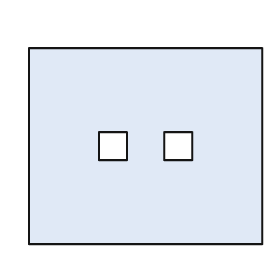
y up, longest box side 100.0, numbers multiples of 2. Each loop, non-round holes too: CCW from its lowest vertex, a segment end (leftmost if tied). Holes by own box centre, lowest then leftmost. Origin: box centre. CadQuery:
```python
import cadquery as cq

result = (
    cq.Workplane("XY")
    .moveTo(-50.0, -42.0)
    .lineTo(50.0, -42.0)
    .lineTo(50.0, 42.0)
    .lineTo(-50.0, 42.0)
    .close()
    .moveTo(-20.0, -6.0)
    .lineTo(-8.0, -6.0)
    .lineTo(-8.0, 6.0)
    .lineTo(-20.0, 6.0)
    .close()
    .moveTo(8.0, -6.0)
    .lineTo(20.0, -6.0)
    .lineTo(20.0, 6.0)
    .lineTo(8.0, 6.0)
    .close()
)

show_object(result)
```